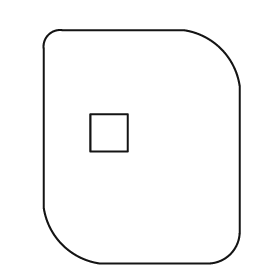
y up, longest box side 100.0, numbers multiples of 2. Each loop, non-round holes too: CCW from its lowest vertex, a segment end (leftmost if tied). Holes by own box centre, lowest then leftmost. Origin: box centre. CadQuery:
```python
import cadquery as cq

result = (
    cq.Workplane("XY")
    .moveTo(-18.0, -50.0)
    .lineTo(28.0, -50.0)
    .threePointArc((38.0, -46.0), (42.0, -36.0))
    .lineTo(42.0, 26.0)
    .threePointArc((34.0, 42.0), (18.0, 50.0))
    .lineTo(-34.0, 50.0)
    .threePointArc((-40.0, 48.0), (-42.0, 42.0))
    .lineTo(-42.0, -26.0)
    .threePointArc((-34.0, -42.0), (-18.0, -50.0))
    .close()
    .moveTo(-22.0, -2.0)
    .lineTo(-6.0, -2.0)
    .lineTo(-6.0, 14.0)
    .lineTo(-22.0, 14.0)
    .close()
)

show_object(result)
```